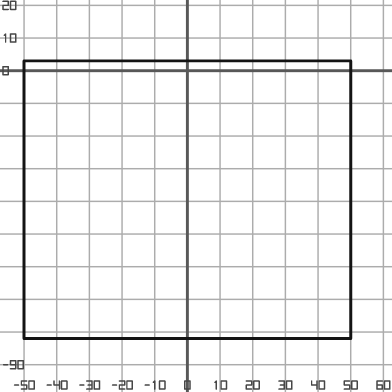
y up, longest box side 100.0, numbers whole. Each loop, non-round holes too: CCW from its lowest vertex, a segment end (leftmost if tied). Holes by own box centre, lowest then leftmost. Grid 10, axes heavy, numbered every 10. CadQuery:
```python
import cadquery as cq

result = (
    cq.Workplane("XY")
    .moveTo(-50.0, -82.0)
    .lineTo(50.0, -82.0)
    .lineTo(50.0, 3.0)
    .lineTo(-50.0, 3.0)
    .close()
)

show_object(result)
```